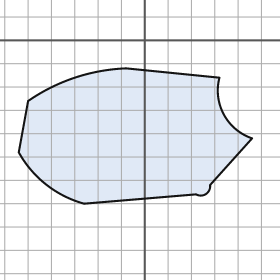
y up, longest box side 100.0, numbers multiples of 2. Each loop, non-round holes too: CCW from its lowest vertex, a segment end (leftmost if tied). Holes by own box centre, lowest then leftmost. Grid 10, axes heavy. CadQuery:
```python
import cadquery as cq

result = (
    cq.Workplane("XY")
    .moveTo(-26.0, -70.0)
    .lineTo(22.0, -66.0)
    .threePointArc((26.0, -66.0), (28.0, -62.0))
    .lineTo(46.0, -42.0)
    .threePointArc((34.0, -32.0), (32.0, -16.0))
    .lineTo(-8.0, -12.0)
    .threePointArc((-30.0, -16.0), (-50.0, -26.0))
    .lineTo(-54.0, -48.0)
    .threePointArc((-42.0, -62.0), (-26.0, -70.0))
    .close()
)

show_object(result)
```